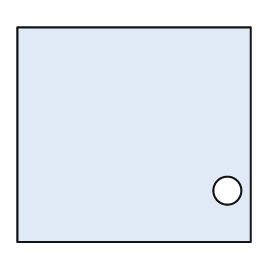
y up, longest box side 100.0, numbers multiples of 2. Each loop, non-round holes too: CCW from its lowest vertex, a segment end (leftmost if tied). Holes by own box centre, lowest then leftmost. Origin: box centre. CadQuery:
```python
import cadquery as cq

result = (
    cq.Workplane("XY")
    .moveTo(-50.0, -46.0)
    .lineTo(50.0, -46.0)
    .lineTo(50.0, 46.0)
    .lineTo(-50.0, 46.0)
    .close()
    .moveTo(40.0, -24.0)
    .circle(6.0)
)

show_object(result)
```